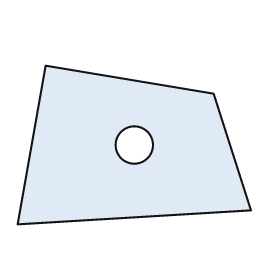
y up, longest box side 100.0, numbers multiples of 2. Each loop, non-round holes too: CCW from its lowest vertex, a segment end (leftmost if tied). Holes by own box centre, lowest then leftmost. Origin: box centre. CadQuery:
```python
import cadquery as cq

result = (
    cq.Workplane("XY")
    .moveTo(-50.0, -34.0)
    .lineTo(50.0, -28.0)
    .lineTo(34.0, 22.0)
    .lineTo(-38.0, 34.0)
    .close()
    .moveTo(0.0, 0.0)
    .circle(8.0)
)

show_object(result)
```